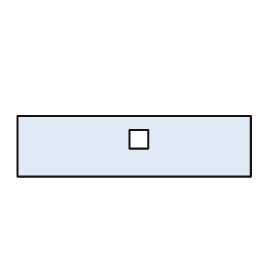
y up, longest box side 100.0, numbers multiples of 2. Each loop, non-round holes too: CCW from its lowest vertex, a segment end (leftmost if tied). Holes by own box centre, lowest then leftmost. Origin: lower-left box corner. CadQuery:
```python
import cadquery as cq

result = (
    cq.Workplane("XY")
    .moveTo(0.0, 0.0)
    .lineTo(100.0, 0.0)
    .lineTo(100.0, 26.0)
    .lineTo(0.0, 26.0)
    .close()
    .moveTo(48.0, 12.0)
    .lineTo(56.0, 12.0)
    .lineTo(56.0, 20.0)
    .lineTo(48.0, 20.0)
    .close()
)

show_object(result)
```